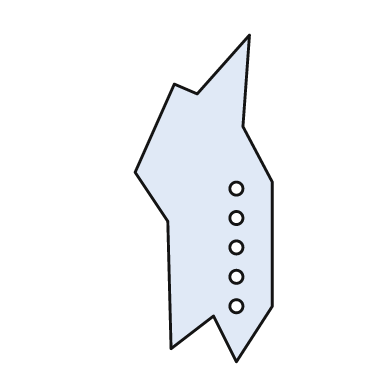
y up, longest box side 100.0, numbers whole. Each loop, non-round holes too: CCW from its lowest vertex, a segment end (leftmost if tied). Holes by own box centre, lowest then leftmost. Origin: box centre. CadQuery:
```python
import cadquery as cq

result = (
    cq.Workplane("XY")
    .moveTo(10.0, -50.0)
    .lineTo(21.0, -33.0)
    .lineTo(21.0, 5.0)
    .lineTo(12.0, 22.0)
    .lineTo(14.0, 50.0)
    .lineTo(-2.0, 32.0)
    .lineTo(-9.0, 35.0)
    .lineTo(-21.0, 8.0)
    .lineTo(-11.0, -7.0)
    .lineTo(-10.0, -46.0)
    .lineTo(3.0, -36.0)
    .close()
    .moveTo(10.0, -33.0)
    .circle(2.0)
    .moveTo(10.0, -24.0)
    .circle(2.0)
    .moveTo(10.0, -15.0)
    .circle(2.0)
    .moveTo(10.0, -6.0)
    .circle(2.0)
    .moveTo(10.0, 3.0)
    .circle(2.0)
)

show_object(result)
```